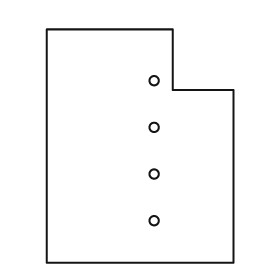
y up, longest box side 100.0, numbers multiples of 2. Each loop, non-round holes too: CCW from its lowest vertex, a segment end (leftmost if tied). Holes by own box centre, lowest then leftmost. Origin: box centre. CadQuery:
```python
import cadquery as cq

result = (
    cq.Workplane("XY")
    .moveTo(-40.0, -50.0)
    .lineTo(40.0, -50.0)
    .lineTo(40.0, 24.0)
    .lineTo(14.0, 24.0)
    .lineTo(14.0, 50.0)
    .lineTo(-40.0, 50.0)
    .close()
    .moveTo(6.0, -32.0)
    .circle(2.0)
    .moveTo(6.0, -12.0)
    .circle(2.0)
    .moveTo(6.0, 8.0)
    .circle(2.0)
    .moveTo(6.0, 28.0)
    .circle(2.0)
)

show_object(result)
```